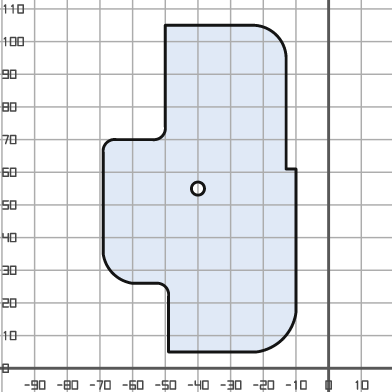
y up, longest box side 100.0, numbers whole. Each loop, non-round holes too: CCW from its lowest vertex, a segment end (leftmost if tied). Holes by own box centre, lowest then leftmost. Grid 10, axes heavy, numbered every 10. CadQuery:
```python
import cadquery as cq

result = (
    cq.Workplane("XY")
    .moveTo(-49.0, 5.0)
    .lineTo(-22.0, 5.0)
    .threePointArc((-14.0, 9.0), (-10.0, 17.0))
    .lineTo(-10.0, 61.0)
    .lineTo(-13.0, 61.0)
    .lineTo(-13.0, 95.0)
    .threePointArc((-16.0, 102.0), (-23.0, 105.0))
    .lineTo(-50.0, 105.0)
    .lineTo(-50.0, 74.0)
    .threePointArc((-51.0, 71.0), (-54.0, 70.0))
    .lineTo(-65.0, 70.0)
    .threePointArc((-68.0, 69.0), (-69.0, 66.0))
    .lineTo(-69.0, 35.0)
    .threePointArc((-66.0, 29.0), (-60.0, 26.0))
    .lineTo(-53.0, 26.0)
    .threePointArc((-50.0, 25.0), (-49.0, 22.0))
    .close()
    .moveTo(-40.0, 55.0)
    .circle(2.0)
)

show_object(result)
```